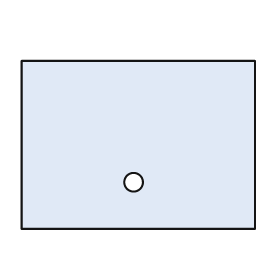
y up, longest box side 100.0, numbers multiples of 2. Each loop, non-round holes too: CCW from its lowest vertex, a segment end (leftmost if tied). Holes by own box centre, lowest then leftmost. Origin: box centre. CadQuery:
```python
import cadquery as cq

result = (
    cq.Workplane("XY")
    .moveTo(-50.0, -36.0)
    .lineTo(50.0, -36.0)
    .lineTo(50.0, 36.0)
    .lineTo(-50.0, 36.0)
    .close()
    .moveTo(-2.0, -16.0)
    .circle(4.0)
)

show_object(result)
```